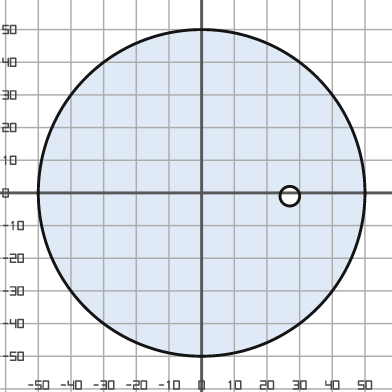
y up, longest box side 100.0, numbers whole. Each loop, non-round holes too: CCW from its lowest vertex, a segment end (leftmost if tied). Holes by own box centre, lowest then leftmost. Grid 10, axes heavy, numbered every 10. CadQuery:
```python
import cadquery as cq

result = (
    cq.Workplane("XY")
    .moveTo(0.0, 0.0)
    .circle(50.0)
    .moveTo(27.0, -1.0)
    .circle(3.0)
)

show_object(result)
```